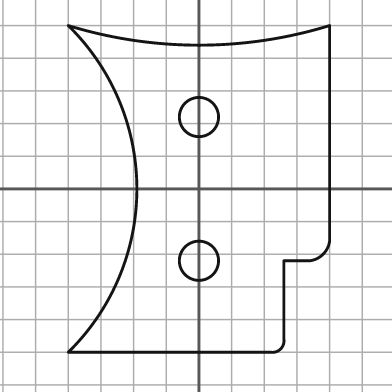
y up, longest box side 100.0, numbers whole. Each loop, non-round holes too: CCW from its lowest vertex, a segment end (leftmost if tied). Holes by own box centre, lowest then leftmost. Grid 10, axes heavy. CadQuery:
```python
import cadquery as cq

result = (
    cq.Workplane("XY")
    .moveTo(-40.0, -50.0)
    .lineTo(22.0, -50.0)
    .threePointArc((25.0, -49.0), (26.0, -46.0))
    .lineTo(26.0, -22.0)
    .lineTo(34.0, -22.0)
    .threePointArc((38.0, -20.0), (40.0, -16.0))
    .lineTo(40.0, 50.0)
    .threePointArc((0.0, 44.0), (-40.0, 50.0))
    .threePointArc((-19.0, 0.0), (-40.0, -50.0))
    .close()
    .moveTo(0.0, -22.0)
    .circle(6.0)
    .moveTo(0.0, 22.0)
    .circle(6.0)
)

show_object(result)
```